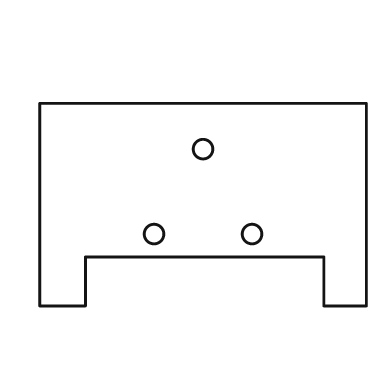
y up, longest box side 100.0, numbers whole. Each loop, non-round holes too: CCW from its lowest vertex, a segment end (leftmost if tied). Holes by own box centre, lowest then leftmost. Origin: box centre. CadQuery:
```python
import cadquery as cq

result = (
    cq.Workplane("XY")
    .moveTo(-50.0, -31.0)
    .lineTo(-36.0, -31.0)
    .lineTo(-36.0, -16.0)
    .lineTo(37.0, -16.0)
    .lineTo(37.0, -31.0)
    .lineTo(50.0, -31.0)
    .lineTo(50.0, 31.0)
    .lineTo(-50.0, 31.0)
    .close()
    .moveTo(-15.0, -9.0)
    .circle(3.0)
    .moveTo(15.0, -9.0)
    .circle(3.0)
    .moveTo(0.0, 17.0)
    .circle(3.0)
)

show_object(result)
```